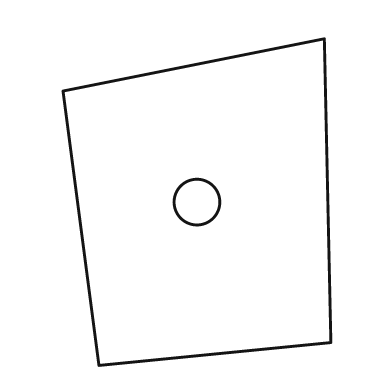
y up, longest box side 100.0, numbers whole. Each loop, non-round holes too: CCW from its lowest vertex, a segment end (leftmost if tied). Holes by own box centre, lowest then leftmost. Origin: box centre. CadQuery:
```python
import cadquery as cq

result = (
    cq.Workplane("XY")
    .moveTo(-30.0, -50.0)
    .lineTo(41.0, -43.0)
    .lineTo(39.0, 50.0)
    .lineTo(-41.0, 34.0)
    .close()
    .moveTo(0.0, 0.0)
    .circle(7.0)
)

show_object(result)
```